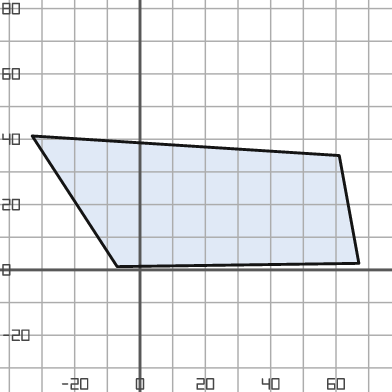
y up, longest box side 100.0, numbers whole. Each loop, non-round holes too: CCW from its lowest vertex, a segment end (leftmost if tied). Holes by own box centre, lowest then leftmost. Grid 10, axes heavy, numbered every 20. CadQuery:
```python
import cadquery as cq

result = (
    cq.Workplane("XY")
    .moveTo(-7.0, 1.0)
    .lineTo(67.0, 2.0)
    .lineTo(61.0, 35.0)
    .lineTo(-33.0, 41.0)
    .close()
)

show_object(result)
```